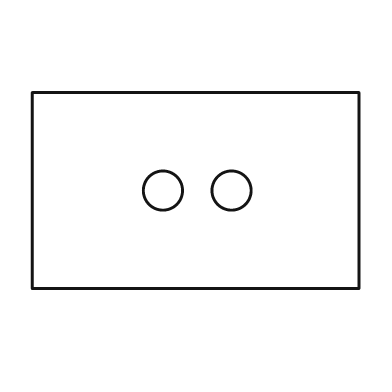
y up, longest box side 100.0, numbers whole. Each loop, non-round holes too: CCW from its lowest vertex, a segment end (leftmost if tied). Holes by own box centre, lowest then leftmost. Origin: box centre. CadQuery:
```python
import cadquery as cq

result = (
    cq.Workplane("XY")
    .moveTo(-50.0, -30.0)
    .lineTo(50.0, -30.0)
    .lineTo(50.0, 30.0)
    .lineTo(-50.0, 30.0)
    .close()
    .moveTo(-10.0, 0.0)
    .circle(6.0)
    .moveTo(11.0, 0.0)
    .circle(6.0)
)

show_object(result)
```